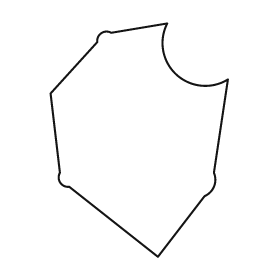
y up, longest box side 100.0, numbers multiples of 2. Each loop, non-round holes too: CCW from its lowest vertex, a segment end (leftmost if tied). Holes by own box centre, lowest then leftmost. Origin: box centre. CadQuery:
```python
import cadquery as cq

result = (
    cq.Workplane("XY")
    .moveTo(8.0, -50.0)
    .lineTo(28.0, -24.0)
    .threePointArc((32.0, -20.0), (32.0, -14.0))
    .lineTo(38.0, 26.0)
    .threePointArc((16.0, 28.0), (12.0, 50.0))
    .lineTo(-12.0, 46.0)
    .threePointArc((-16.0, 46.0), (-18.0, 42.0))
    .lineTo(-38.0, 20.0)
    .lineTo(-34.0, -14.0)
    .threePointArc((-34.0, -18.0), (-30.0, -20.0))
    .close()
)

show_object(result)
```